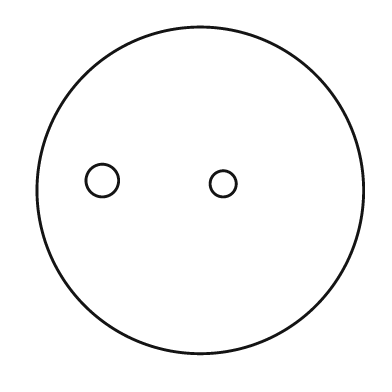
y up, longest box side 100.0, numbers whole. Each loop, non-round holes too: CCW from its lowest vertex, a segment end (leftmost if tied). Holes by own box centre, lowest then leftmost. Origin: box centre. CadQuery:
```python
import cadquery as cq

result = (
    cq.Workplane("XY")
    .moveTo(0.0, 0.0)
    .circle(50.0)
    .moveTo(7.0, 2.0)
    .circle(4.0)
    .moveTo(-30.0, 3.0)
    .circle(5.0)
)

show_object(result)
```